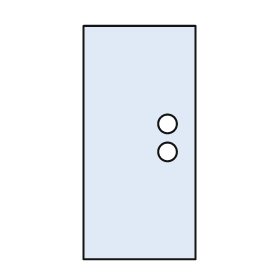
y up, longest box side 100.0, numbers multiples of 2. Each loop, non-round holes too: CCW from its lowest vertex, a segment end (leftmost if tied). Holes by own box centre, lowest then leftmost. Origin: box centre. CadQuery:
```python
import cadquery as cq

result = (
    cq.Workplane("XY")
    .moveTo(-24.0, -50.0)
    .lineTo(24.0, -50.0)
    .lineTo(24.0, 50.0)
    .lineTo(-24.0, 50.0)
    .close()
    .moveTo(12.0, -4.0)
    .circle(4.0)
    .moveTo(12.0, 8.0)
    .circle(4.0)
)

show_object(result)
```